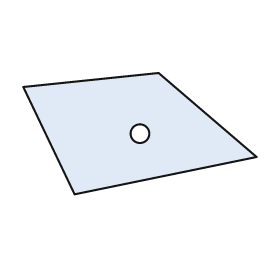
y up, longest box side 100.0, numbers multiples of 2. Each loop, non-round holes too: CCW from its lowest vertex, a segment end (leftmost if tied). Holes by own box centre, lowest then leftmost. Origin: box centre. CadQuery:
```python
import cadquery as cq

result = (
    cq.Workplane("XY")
    .moveTo(-28.0, -26.0)
    .lineTo(50.0, -10.0)
    .lineTo(8.0, 26.0)
    .lineTo(-50.0, 20.0)
    .close()
    .moveTo(0.0, 0.0)
    .circle(4.0)
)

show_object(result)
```